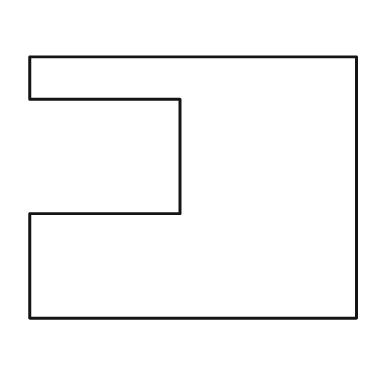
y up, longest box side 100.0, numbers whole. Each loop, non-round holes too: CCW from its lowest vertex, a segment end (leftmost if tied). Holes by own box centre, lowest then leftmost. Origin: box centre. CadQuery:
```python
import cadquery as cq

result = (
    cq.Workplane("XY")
    .moveTo(-50.0, -40.0)
    .lineTo(50.0, -40.0)
    .lineTo(50.0, 40.0)
    .lineTo(-50.0, 40.0)
    .lineTo(-50.0, 27.0)
    .lineTo(-4.0, 27.0)
    .lineTo(-4.0, -8.0)
    .lineTo(-50.0, -8.0)
    .close()
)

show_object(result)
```